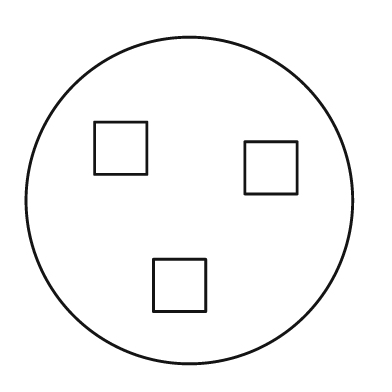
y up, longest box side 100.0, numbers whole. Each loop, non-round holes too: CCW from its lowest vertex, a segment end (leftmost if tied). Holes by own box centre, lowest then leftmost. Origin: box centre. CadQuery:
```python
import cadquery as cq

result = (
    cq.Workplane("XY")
    .moveTo(0.0, 0.0)
    .circle(50.0)
    .moveTo(-11.0, -34.0)
    .lineTo(5.0, -34.0)
    .lineTo(5.0, -18.0)
    .lineTo(-11.0, -18.0)
    .close()
    .moveTo(17.0, 2.0)
    .lineTo(33.0, 2.0)
    .lineTo(33.0, 18.0)
    .lineTo(17.0, 18.0)
    .close()
    .moveTo(-29.0, 8.0)
    .lineTo(-13.0, 8.0)
    .lineTo(-13.0, 24.0)
    .lineTo(-29.0, 24.0)
    .close()
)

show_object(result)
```